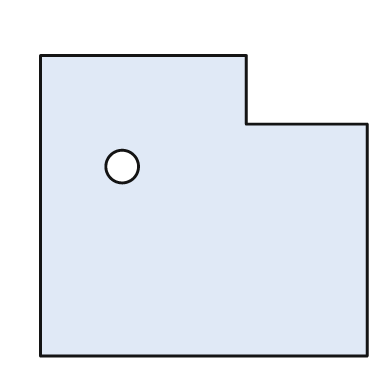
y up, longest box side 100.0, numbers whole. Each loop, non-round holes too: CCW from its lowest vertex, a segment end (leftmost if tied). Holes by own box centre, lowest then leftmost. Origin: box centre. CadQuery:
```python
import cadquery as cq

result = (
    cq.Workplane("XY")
    .moveTo(-50.0, -46.0)
    .lineTo(50.0, -46.0)
    .lineTo(50.0, 25.0)
    .lineTo(13.0, 25.0)
    .lineTo(13.0, 46.0)
    .lineTo(-50.0, 46.0)
    .close()
    .moveTo(-25.0, 12.0)
    .circle(5.0)
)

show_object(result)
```